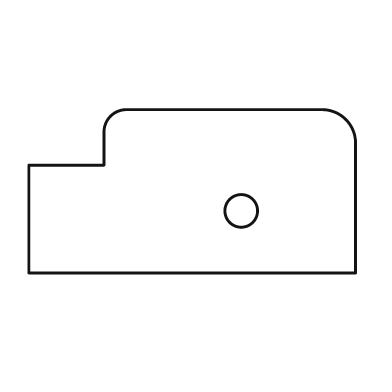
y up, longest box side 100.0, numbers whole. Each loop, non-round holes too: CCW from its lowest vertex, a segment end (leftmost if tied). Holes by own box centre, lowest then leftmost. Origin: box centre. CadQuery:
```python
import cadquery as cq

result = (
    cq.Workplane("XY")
    .moveTo(-50.0, -25.0)
    .lineTo(50.0, -25.0)
    .lineTo(50.0, 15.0)
    .threePointArc((47.0, 22.0), (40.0, 25.0))
    .lineTo(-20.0, 25.0)
    .threePointArc((-25.0, 23.0), (-27.0, 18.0))
    .lineTo(-27.0, 8.0)
    .lineTo(-50.0, 8.0)
    .close()
    .moveTo(15.0, -6.0)
    .circle(5.0)
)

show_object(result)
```